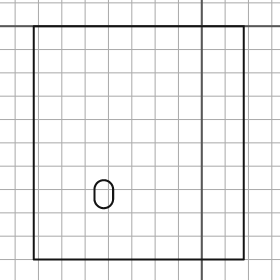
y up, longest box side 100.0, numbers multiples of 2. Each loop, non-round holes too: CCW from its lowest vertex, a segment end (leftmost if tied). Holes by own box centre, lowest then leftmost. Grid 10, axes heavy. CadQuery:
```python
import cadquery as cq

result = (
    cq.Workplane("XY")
    .moveTo(-72.0, -100.0)
    .lineTo(18.0, -100.0)
    .lineTo(18.0, 0.0)
    .lineTo(-72.0, 0.0)
    .close()
    .moveTo(-46.0, -74.0)
    .threePointArc((-42.0, -78.0), (-38.0, -74.0))
    .lineTo(-38.0, -70.0)
    .threePointArc((-42.0, -66.0), (-46.0, -70.0))
    .close()
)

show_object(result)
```